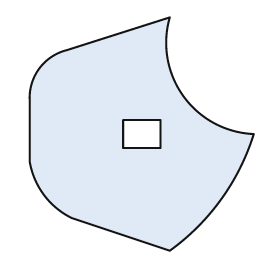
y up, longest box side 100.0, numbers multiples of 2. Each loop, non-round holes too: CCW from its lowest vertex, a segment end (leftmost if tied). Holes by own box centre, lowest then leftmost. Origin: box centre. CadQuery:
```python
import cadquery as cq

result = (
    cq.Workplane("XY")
    .moveTo(12.0, -50.0)
    .threePointArc((34.0, -28.0), (48.0, 0.0))
    .threePointArc((18.0, 16.0), (12.0, 50.0))
    .lineTo(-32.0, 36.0)
    .threePointArc((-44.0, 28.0), (-48.0, 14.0))
    .lineTo(-48.0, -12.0)
    .threePointArc((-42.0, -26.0), (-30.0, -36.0))
    .close()
    .moveTo(-8.0, -6.0)
    .lineTo(8.0, -6.0)
    .lineTo(8.0, 6.0)
    .lineTo(-8.0, 6.0)
    .close()
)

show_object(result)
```